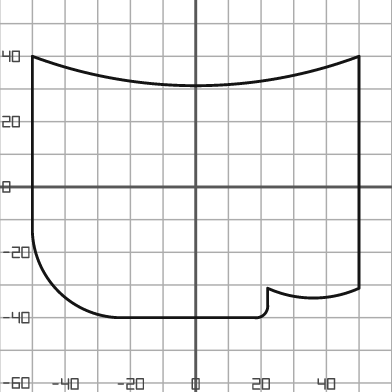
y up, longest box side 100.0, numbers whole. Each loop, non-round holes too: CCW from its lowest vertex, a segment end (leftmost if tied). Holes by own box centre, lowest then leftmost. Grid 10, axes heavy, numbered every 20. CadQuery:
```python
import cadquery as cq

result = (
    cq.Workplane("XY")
    .moveTo(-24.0, -40.0)
    .lineTo(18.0, -40.0)
    .threePointArc((21.0, -39.0), (22.0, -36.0))
    .lineTo(22.0, -31.0)
    .threePointArc((36.0, -34.0), (50.0, -31.0))
    .lineTo(50.0, 40.0)
    .threePointArc((0.0, 31.0), (-50.0, 40.0))
    .lineTo(-50.0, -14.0)
    .threePointArc((-42.0, -32.0), (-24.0, -40.0))
    .close()
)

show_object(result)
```